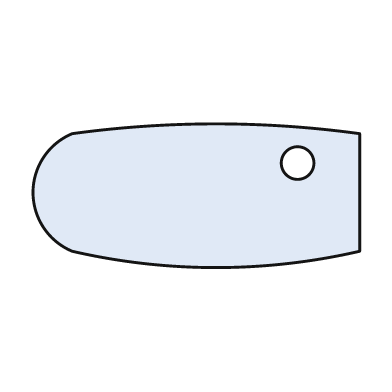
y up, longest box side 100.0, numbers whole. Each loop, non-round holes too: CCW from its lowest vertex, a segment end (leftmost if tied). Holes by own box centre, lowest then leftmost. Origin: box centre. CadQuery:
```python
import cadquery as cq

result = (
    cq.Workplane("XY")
    .moveTo(-38.0, -17.0)
    .threePointArc((6.0, -22.0), (50.0, -17.0))
    .lineTo(50.0, 19.0)
    .threePointArc((6.0, 22.0), (-38.0, 19.0))
    .threePointArc((-50.0, 1.0), (-38.0, -17.0))
    .close()
    .moveTo(31.0, 10.0)
    .circle(5.0)
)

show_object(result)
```